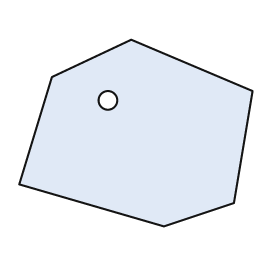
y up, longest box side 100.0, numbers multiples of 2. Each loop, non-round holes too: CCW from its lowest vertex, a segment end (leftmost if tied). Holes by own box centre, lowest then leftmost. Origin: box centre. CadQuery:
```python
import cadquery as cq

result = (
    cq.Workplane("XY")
    .moveTo(12.0, -40.0)
    .lineTo(42.0, -30.0)
    .lineTo(50.0, 18.0)
    .lineTo(-2.0, 40.0)
    .lineTo(-36.0, 24.0)
    .lineTo(-50.0, -22.0)
    .close()
    .moveTo(-12.0, 14.0)
    .circle(4.0)
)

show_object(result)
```